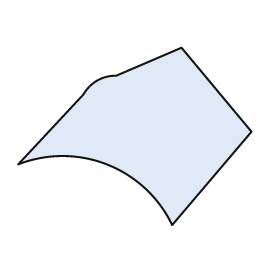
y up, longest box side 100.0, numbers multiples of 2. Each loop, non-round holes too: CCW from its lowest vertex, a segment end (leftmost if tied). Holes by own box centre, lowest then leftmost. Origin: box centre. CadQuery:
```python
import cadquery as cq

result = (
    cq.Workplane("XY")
    .moveTo(16.0, -38.0)
    .lineTo(50.0, 2.0)
    .lineTo(20.0, 38.0)
    .lineTo(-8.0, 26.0)
    .threePointArc((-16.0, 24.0), (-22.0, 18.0))
    .lineTo(-50.0, -12.0)
    .threePointArc((-12.0, -12.0), (16.0, -38.0))
    .close()
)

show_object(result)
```